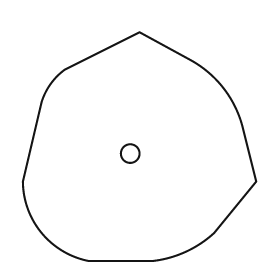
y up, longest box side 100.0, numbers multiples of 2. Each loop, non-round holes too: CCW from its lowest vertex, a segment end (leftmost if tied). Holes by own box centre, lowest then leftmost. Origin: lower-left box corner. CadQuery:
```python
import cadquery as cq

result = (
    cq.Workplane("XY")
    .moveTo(28.0, 0.0)
    .lineTo(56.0, 0.0)
    .threePointArc((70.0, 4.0), (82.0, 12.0))
    .lineTo(100.0, 34.0)
    .lineTo(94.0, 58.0)
    .threePointArc((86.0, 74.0), (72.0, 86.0))
    .lineTo(50.0, 98.0)
    .lineTo(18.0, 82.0)
    .threePointArc((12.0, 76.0), (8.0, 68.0))
    .lineTo(0.0, 34.0)
    .threePointArc((8.0, 12.0), (28.0, 0.0))
    .close()
    .moveTo(46.0, 46.0)
    .circle(4.0)
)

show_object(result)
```